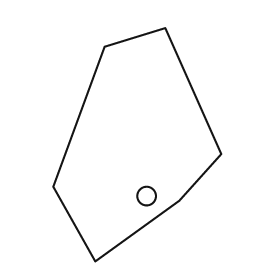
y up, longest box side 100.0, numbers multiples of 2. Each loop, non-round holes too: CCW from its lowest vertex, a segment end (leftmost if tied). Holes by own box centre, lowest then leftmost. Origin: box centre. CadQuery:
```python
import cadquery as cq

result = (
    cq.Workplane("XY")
    .moveTo(-18.0, -50.0)
    .lineTo(18.0, -24.0)
    .lineTo(36.0, -4.0)
    .lineTo(12.0, 50.0)
    .lineTo(-14.0, 42.0)
    .lineTo(-36.0, -18.0)
    .close()
    .moveTo(4.0, -22.0)
    .circle(4.0)
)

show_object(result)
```